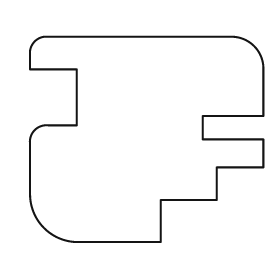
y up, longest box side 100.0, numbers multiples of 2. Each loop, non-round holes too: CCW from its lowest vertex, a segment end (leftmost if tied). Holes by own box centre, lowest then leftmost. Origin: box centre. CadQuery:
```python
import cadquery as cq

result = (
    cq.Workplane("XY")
    .moveTo(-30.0, -44.0)
    .lineTo(6.0, -44.0)
    .lineTo(6.0, -26.0)
    .lineTo(30.0, -26.0)
    .lineTo(30.0, -12.0)
    .lineTo(50.0, -12.0)
    .lineTo(50.0, 0.0)
    .lineTo(24.0, 0.0)
    .lineTo(24.0, 10.0)
    .lineTo(50.0, 10.0)
    .lineTo(50.0, 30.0)
    .threePointArc((46.0, 40.0), (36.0, 44.0))
    .lineTo(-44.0, 44.0)
    .threePointArc((-48.0, 42.0), (-50.0, 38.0))
    .lineTo(-50.0, 30.0)
    .lineTo(-30.0, 30.0)
    .lineTo(-30.0, 6.0)
    .lineTo(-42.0, 6.0)
    .threePointArc((-48.0, 4.0), (-50.0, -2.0))
    .lineTo(-50.0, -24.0)
    .threePointArc((-44.0, -38.0), (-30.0, -44.0))
    .close()
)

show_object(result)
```